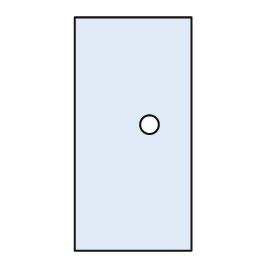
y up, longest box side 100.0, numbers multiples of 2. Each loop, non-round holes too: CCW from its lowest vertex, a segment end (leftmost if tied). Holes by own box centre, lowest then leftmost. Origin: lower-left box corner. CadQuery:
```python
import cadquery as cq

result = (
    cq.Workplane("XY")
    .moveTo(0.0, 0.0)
    .lineTo(50.0, 0.0)
    .lineTo(50.0, 100.0)
    .lineTo(0.0, 100.0)
    .close()
    .moveTo(32.0, 54.0)
    .circle(4.0)
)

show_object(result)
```